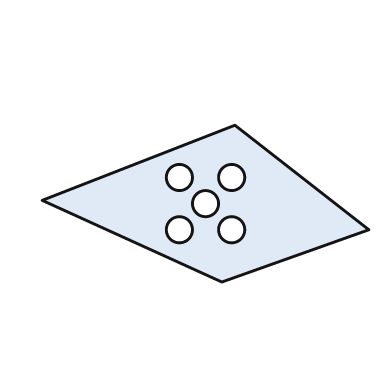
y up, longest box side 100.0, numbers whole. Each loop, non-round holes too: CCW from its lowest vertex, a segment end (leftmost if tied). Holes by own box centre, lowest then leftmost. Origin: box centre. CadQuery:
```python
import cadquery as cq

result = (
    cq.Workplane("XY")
    .moveTo(5.0, -24.0)
    .lineTo(50.0, -8.0)
    .lineTo(9.0, 24.0)
    .lineTo(-50.0, 1.0)
    .close()
    .moveTo(-8.0, -8.0)
    .circle(4.0)
    .moveTo(8.0, -8.0)
    .circle(4.0)
    .moveTo(0.0, 0.0)
    .circle(4.0)
    .moveTo(-8.0, 8.0)
    .circle(4.0)
    .moveTo(8.0, 8.0)
    .circle(4.0)
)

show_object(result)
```